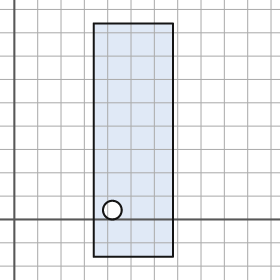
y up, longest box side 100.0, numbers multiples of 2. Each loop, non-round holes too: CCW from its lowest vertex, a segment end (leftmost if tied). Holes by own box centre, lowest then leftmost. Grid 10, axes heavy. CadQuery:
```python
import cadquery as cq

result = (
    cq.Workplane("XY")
    .moveTo(34.0, -16.0)
    .lineTo(68.0, -16.0)
    .lineTo(68.0, 84.0)
    .lineTo(34.0, 84.0)
    .close()
    .moveTo(42.0, 4.0)
    .circle(4.0)
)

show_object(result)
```